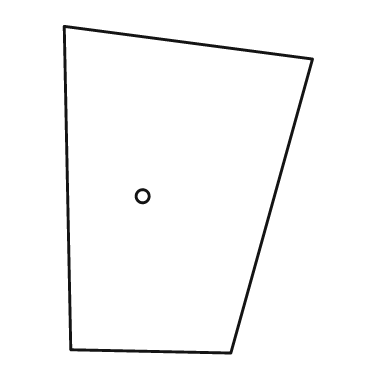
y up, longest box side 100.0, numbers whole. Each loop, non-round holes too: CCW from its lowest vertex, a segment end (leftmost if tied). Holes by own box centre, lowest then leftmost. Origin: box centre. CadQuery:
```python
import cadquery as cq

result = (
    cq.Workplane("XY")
    .moveTo(13.0, -50.0)
    .lineTo(38.0, 40.0)
    .lineTo(-38.0, 50.0)
    .lineTo(-36.0, -49.0)
    .close()
    .moveTo(-14.0, -2.0)
    .circle(2.0)
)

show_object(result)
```